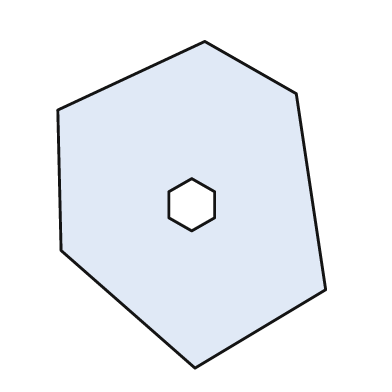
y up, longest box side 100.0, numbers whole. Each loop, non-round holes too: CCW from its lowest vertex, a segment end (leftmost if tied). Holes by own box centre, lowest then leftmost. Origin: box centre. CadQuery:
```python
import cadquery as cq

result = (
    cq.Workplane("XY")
    .moveTo(1.0, -50.0)
    .lineTo(41.0, -26.0)
    .lineTo(32.0, 34.0)
    .lineTo(4.0, 50.0)
    .lineTo(-41.0, 29.0)
    .lineTo(-40.0, -14.0)
    .close()
    .moveTo(0.0, -8.0)
    .lineTo(7.0, -4.0)
    .lineTo(7.0, 4.0)
    .lineTo(0.0, 8.0)
    .lineTo(-7.0, 4.0)
    .lineTo(-7.0, -4.0)
    .close()
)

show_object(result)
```